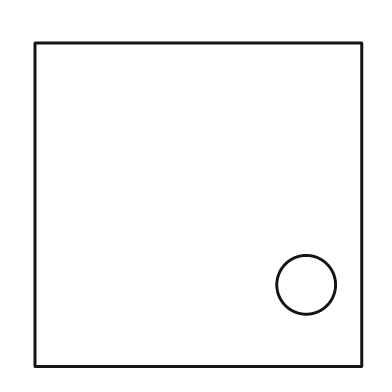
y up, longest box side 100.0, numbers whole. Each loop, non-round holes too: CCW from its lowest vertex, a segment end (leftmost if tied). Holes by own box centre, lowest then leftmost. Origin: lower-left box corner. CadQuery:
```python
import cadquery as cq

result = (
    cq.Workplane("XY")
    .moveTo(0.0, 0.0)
    .lineTo(100.0, 0.0)
    .lineTo(100.0, 99.0)
    .lineTo(0.0, 99.0)
    .close()
    .moveTo(83.0, 25.0)
    .circle(9.0)
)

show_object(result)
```